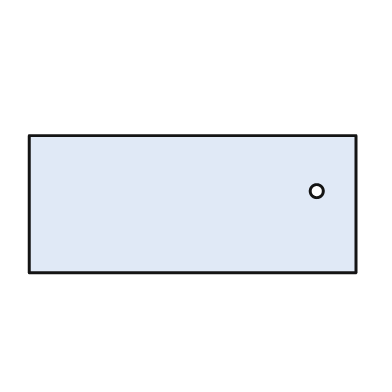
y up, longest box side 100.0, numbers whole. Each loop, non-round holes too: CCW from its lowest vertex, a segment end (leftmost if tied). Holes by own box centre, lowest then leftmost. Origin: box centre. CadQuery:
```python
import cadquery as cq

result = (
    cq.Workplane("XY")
    .moveTo(-50.0, -21.0)
    .lineTo(50.0, -21.0)
    .lineTo(50.0, 21.0)
    .lineTo(-50.0, 21.0)
    .close()
    .moveTo(38.0, 4.0)
    .circle(2.0)
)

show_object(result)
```